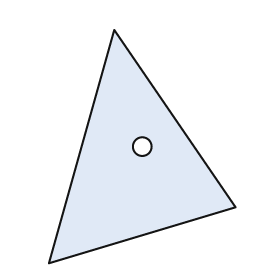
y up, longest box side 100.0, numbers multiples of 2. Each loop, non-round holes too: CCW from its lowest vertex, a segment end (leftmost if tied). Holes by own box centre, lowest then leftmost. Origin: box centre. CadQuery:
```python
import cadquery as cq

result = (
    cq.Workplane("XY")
    .moveTo(-40.0, -50.0)
    .lineTo(40.0, -26.0)
    .lineTo(-12.0, 50.0)
    .close()
    .moveTo(0.0, 0.0)
    .circle(4.0)
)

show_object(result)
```